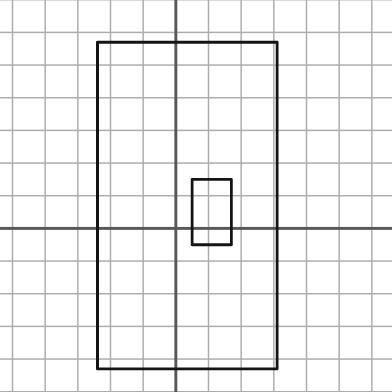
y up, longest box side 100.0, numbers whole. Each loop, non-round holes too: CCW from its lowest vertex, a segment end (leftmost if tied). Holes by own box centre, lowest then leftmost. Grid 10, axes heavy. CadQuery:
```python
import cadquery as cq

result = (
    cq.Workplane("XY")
    .moveTo(-24.0, -43.0)
    .lineTo(31.0, -43.0)
    .lineTo(31.0, 57.0)
    .lineTo(-24.0, 57.0)
    .close()
    .moveTo(5.0, -5.0)
    .lineTo(17.0, -5.0)
    .lineTo(17.0, 15.0)
    .lineTo(5.0, 15.0)
    .close()
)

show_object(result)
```